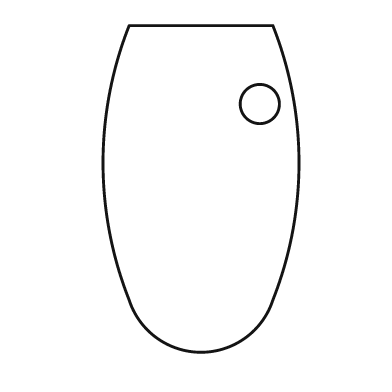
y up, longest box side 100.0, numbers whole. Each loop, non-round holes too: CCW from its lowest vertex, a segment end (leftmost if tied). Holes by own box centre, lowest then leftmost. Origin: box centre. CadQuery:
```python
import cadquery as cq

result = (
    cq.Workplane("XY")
    .moveTo(-22.0, -34.0)
    .threePointArc((0.0, -50.0), (22.0, -34.0))
    .threePointArc((30.0, 8.0), (22.0, 50.0))
    .lineTo(-22.0, 50.0)
    .threePointArc((-30.0, 8.0), (-22.0, -34.0))
    .close()
    .moveTo(18.0, 26.0)
    .circle(6.0)
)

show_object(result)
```